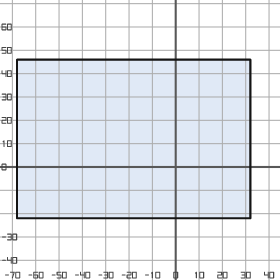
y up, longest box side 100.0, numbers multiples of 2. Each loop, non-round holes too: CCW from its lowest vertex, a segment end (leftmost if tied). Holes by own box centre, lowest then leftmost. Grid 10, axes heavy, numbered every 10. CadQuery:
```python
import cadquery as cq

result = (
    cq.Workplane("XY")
    .moveTo(-68.0, -22.0)
    .lineTo(32.0, -22.0)
    .lineTo(32.0, 46.0)
    .lineTo(-68.0, 46.0)
    .close()
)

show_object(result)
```